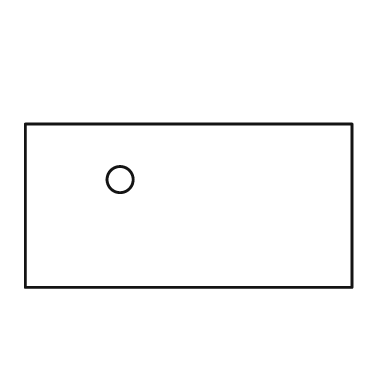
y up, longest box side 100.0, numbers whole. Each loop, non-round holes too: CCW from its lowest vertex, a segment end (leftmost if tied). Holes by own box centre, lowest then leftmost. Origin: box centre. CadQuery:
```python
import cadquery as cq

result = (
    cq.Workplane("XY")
    .moveTo(-50.0, -25.0)
    .lineTo(50.0, -25.0)
    .lineTo(50.0, 25.0)
    .lineTo(-50.0, 25.0)
    .close()
    .moveTo(-21.0, 8.0)
    .circle(4.0)
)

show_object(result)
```